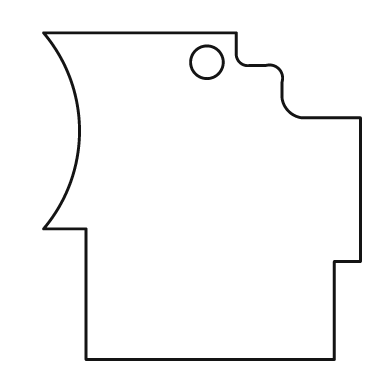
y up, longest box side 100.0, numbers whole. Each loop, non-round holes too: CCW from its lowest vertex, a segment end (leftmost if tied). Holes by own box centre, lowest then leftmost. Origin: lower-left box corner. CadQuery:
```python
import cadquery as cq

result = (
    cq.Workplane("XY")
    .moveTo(13.0, 0.0)
    .lineTo(89.0, 0.0)
    .lineTo(89.0, 30.0)
    .lineTo(97.0, 30.0)
    .lineTo(97.0, 74.0)
    .lineTo(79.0, 74.0)
    .threePointArc((75.0, 76.0), (73.0, 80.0))
    .lineTo(73.0, 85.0)
    .threePointArc((72.0, 89.0), (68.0, 90.0))
    .lineTo(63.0, 90.0)
    .threePointArc((60.0, 91.0), (59.0, 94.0))
    .lineTo(59.0, 100.0)
    .lineTo(0.0, 100.0)
    .threePointArc((11.0, 70.0), (0.0, 40.0))
    .lineTo(13.0, 40.0)
    .close()
    .moveTo(50.0, 91.0)
    .circle(5.0)
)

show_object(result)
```